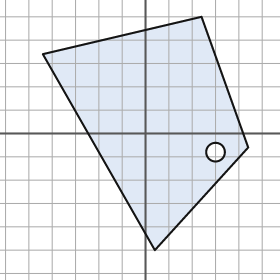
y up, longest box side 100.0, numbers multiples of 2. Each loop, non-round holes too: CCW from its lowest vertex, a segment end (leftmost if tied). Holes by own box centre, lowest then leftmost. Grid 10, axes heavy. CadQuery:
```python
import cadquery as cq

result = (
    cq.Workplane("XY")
    .moveTo(4.0, -50.0)
    .lineTo(44.0, -6.0)
    .lineTo(24.0, 50.0)
    .lineTo(-44.0, 34.0)
    .close()
    .moveTo(30.0, -8.0)
    .circle(4.0)
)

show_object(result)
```